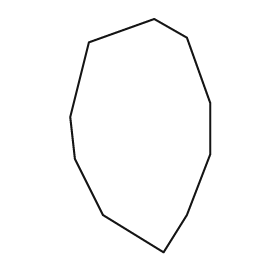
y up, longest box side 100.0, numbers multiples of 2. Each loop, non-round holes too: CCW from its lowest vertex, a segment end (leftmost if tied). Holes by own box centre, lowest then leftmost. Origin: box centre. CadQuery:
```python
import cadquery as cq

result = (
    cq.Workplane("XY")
    .moveTo(10.0, -50.0)
    .lineTo(20.0, -34.0)
    .lineTo(30.0, -8.0)
    .lineTo(30.0, 14.0)
    .lineTo(20.0, 42.0)
    .lineTo(6.0, 50.0)
    .lineTo(-22.0, 40.0)
    .lineTo(-30.0, 8.0)
    .lineTo(-28.0, -10.0)
    .lineTo(-16.0, -34.0)
    .close()
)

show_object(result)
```